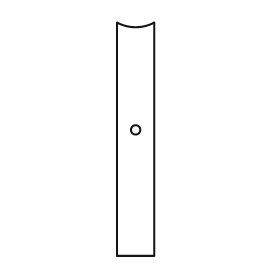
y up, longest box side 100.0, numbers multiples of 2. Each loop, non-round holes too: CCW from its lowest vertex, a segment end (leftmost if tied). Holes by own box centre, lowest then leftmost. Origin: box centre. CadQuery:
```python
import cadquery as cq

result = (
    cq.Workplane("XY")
    .moveTo(-8.0, -50.0)
    .lineTo(8.0, -50.0)
    .lineTo(8.0, 50.0)
    .threePointArc((0.0, 48.0), (-8.0, 50.0))
    .close()
    .moveTo(0.0, 4.0)
    .circle(2.0)
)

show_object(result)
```